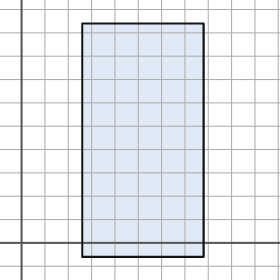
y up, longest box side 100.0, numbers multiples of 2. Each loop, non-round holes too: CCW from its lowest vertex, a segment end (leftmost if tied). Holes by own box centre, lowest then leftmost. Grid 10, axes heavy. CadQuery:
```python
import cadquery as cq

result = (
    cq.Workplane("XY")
    .moveTo(26.0, -6.0)
    .lineTo(78.0, -6.0)
    .lineTo(78.0, 94.0)
    .lineTo(26.0, 94.0)
    .close()
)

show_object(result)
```